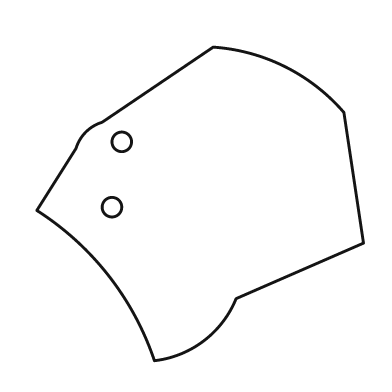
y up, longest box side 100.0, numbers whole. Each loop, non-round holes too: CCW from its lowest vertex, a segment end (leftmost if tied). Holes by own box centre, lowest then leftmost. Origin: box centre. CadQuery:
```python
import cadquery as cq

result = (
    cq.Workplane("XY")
    .moveTo(-14.0, -48.0)
    .threePointArc((1.0, -42.0), (11.0, -29.0))
    .lineTo(50.0, -12.0)
    .lineTo(44.0, 28.0)
    .threePointArc((26.0, 42.0), (4.0, 48.0))
    .lineTo(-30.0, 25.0)
    .threePointArc((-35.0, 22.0), (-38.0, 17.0))
    .lineTo(-50.0, -2.0)
    .threePointArc((-28.0, -22.0), (-14.0, -48.0))
    .close()
    .moveTo(-27.0, -1.0)
    .circle(3.0)
    .moveTo(-24.0, 19.0)
    .circle(3.0)
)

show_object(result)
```